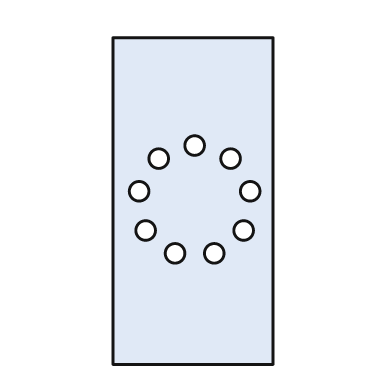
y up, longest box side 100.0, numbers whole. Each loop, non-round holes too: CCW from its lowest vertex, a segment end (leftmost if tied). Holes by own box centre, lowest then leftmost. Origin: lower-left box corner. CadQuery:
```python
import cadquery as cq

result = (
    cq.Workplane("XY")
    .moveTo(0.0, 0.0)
    .lineTo(49.0, 0.0)
    .lineTo(49.0, 100.0)
    .lineTo(0.0, 100.0)
    .close()
    .moveTo(19.0, 34.0)
    .circle(3.0)
    .moveTo(31.0, 34.0)
    .circle(3.0)
    .moveTo(10.0, 41.0)
    .circle(3.0)
    .moveTo(40.0, 41.0)
    .circle(3.0)
    .moveTo(8.0, 53.0)
    .circle(3.0)
    .moveTo(42.0, 53.0)
    .circle(3.0)
    .moveTo(14.0, 63.0)
    .circle(3.0)
    .moveTo(36.0, 63.0)
    .circle(3.0)
    .moveTo(25.0, 67.0)
    .circle(3.0)
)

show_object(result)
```